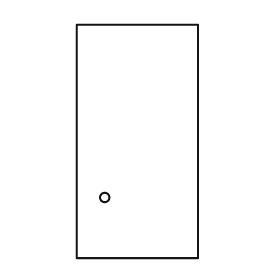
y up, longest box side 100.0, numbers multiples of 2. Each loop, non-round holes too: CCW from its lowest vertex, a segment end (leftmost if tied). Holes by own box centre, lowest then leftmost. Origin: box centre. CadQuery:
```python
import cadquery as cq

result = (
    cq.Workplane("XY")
    .moveTo(-26.0, -50.0)
    .lineTo(26.0, -50.0)
    .lineTo(26.0, 50.0)
    .lineTo(-26.0, 50.0)
    .close()
    .moveTo(-14.0, -24.0)
    .circle(2.0)
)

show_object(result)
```